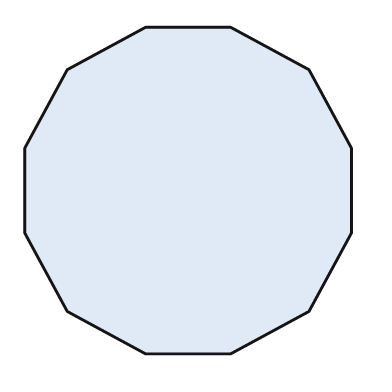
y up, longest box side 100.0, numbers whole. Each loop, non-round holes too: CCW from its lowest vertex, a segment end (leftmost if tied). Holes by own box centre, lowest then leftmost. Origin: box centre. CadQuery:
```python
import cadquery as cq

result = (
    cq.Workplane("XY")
    .moveTo(-13.0, -50.0)
    .lineTo(13.0, -50.0)
    .lineTo(37.0, -37.0)
    .lineTo(50.0, -13.0)
    .lineTo(50.0, 13.0)
    .lineTo(37.0, 37.0)
    .lineTo(13.0, 50.0)
    .lineTo(-13.0, 50.0)
    .lineTo(-37.0, 37.0)
    .lineTo(-50.0, 13.0)
    .lineTo(-50.0, -13.0)
    .lineTo(-37.0, -37.0)
    .close()
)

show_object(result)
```